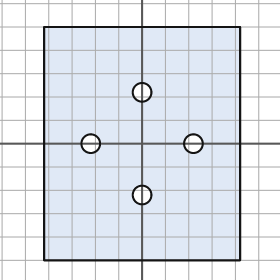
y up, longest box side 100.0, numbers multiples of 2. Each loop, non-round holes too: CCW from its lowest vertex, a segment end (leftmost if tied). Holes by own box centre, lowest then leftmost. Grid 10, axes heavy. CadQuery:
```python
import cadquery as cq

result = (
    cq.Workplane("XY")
    .moveTo(-42.0, -50.0)
    .lineTo(42.0, -50.0)
    .lineTo(42.0, 50.0)
    .lineTo(-42.0, 50.0)
    .close()
    .moveTo(0.0, -22.0)
    .circle(4.0)
    .moveTo(-22.0, 0.0)
    .circle(4.0)
    .moveTo(22.0, 0.0)
    .circle(4.0)
    .moveTo(0.0, 22.0)
    .circle(4.0)
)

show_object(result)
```